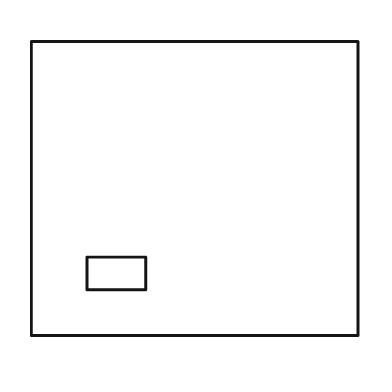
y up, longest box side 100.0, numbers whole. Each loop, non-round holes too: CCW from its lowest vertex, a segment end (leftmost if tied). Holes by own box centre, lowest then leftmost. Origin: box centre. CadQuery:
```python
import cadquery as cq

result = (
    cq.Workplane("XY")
    .moveTo(-50.0, -45.0)
    .lineTo(50.0, -45.0)
    .lineTo(50.0, 45.0)
    .lineTo(-50.0, 45.0)
    .close()
    .moveTo(-33.0, -31.0)
    .lineTo(-15.0, -31.0)
    .lineTo(-15.0, -21.0)
    .lineTo(-33.0, -21.0)
    .close()
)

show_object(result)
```